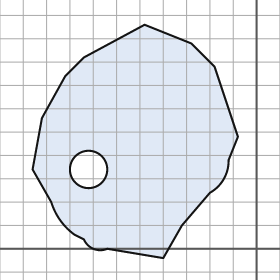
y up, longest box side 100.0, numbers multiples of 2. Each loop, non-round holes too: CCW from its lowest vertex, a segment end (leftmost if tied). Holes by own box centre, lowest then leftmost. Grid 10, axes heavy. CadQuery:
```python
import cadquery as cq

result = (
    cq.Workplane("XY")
    .moveTo(-40.0, -4.0)
    .lineTo(-32.0, 10.0)
    .lineTo(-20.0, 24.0)
    .threePointArc((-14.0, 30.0), (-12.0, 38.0))
    .lineTo(-8.0, 48.0)
    .lineTo(-18.0, 78.0)
    .lineTo(-28.0, 88.0)
    .lineTo(-48.0, 96.0)
    .lineTo(-74.0, 82.0)
    .lineTo(-82.0, 74.0)
    .lineTo(-92.0, 56.0)
    .lineTo(-96.0, 34.0)
    .lineTo(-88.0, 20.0)
    .threePointArc((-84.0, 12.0), (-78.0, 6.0))
    .lineTo(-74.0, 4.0)
    .threePointArc((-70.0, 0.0), (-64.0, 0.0))
    .close()
    .moveTo(-72.0, 34.0)
    .circle(8.0)
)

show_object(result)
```